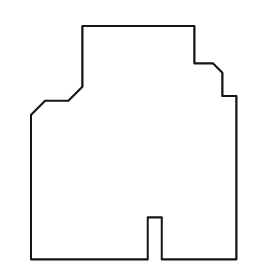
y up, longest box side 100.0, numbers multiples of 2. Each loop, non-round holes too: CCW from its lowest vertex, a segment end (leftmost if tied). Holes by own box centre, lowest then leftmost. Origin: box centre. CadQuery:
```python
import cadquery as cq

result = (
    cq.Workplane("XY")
    .moveTo(-44.0, -50.0)
    .lineTo(6.0, -50.0)
    .lineTo(6.0, -32.0)
    .lineTo(12.0, -32.0)
    .lineTo(12.0, -50.0)
    .lineTo(44.0, -50.0)
    .lineTo(44.0, 20.0)
    .lineTo(38.0, 20.0)
    .lineTo(38.0, 30.0)
    .lineTo(34.0, 34.0)
    .lineTo(26.0, 34.0)
    .lineTo(26.0, 50.0)
    .lineTo(-22.0, 50.0)
    .lineTo(-22.0, 24.0)
    .lineTo(-28.0, 18.0)
    .lineTo(-38.0, 18.0)
    .lineTo(-44.0, 12.0)
    .close()
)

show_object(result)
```